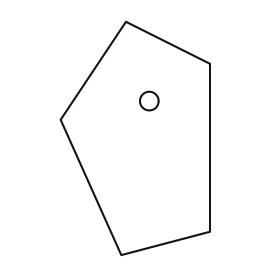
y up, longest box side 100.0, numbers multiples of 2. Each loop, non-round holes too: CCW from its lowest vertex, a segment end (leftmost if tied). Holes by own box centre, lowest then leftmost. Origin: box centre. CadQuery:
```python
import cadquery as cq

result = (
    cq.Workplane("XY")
    .moveTo(-6.0, -50.0)
    .lineTo(32.0, -40.0)
    .lineTo(32.0, 32.0)
    .lineTo(-4.0, 50.0)
    .lineTo(-32.0, 8.0)
    .close()
    .moveTo(6.0, 16.0)
    .circle(4.0)
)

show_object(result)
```